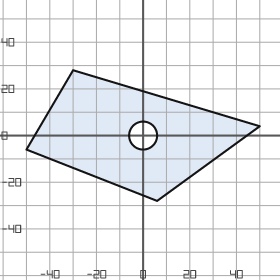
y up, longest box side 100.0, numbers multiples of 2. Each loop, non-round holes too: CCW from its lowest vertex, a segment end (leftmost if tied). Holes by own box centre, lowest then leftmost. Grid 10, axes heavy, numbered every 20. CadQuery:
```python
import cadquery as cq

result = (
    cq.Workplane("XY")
    .moveTo(6.0, -28.0)
    .lineTo(50.0, 4.0)
    .lineTo(-30.0, 28.0)
    .lineTo(-50.0, -6.0)
    .close()
    .moveTo(0.0, 0.0)
    .circle(6.0)
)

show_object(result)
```